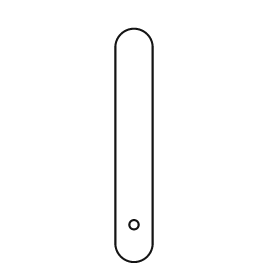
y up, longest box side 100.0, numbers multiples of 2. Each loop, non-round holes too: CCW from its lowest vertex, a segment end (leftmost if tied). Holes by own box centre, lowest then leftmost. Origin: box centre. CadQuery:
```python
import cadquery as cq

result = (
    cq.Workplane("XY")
    .moveTo(-8.0, -42.0)
    .threePointArc((0.0, -50.0), (8.0, -42.0))
    .lineTo(8.0, 42.0)
    .threePointArc((0.0, 50.0), (-8.0, 42.0))
    .close()
    .moveTo(0.0, -34.0)
    .circle(2.0)
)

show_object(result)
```